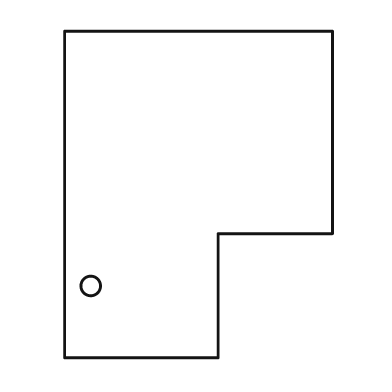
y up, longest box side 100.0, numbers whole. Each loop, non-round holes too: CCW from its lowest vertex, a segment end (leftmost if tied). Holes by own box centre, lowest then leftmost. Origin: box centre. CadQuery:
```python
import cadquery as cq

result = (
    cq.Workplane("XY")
    .moveTo(-41.0, -50.0)
    .lineTo(6.0, -50.0)
    .lineTo(6.0, -12.0)
    .lineTo(41.0, -12.0)
    .lineTo(41.0, 50.0)
    .lineTo(-41.0, 50.0)
    .close()
    .moveTo(-33.0, -28.0)
    .circle(3.0)
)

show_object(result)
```